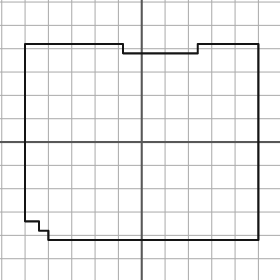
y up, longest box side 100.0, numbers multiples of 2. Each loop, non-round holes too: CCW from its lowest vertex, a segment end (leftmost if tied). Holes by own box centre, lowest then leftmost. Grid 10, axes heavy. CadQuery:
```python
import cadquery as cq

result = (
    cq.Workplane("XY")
    .moveTo(-40.0, -42.0)
    .lineTo(50.0, -42.0)
    .lineTo(50.0, 42.0)
    .lineTo(24.0, 42.0)
    .lineTo(24.0, 38.0)
    .lineTo(-8.0, 38.0)
    .lineTo(-8.0, 42.0)
    .lineTo(-50.0, 42.0)
    .lineTo(-50.0, -34.0)
    .lineTo(-44.0, -34.0)
    .lineTo(-44.0, -38.0)
    .lineTo(-40.0, -38.0)
    .close()
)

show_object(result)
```